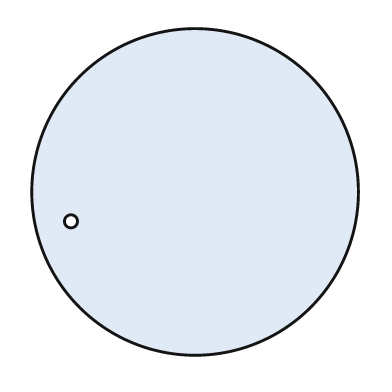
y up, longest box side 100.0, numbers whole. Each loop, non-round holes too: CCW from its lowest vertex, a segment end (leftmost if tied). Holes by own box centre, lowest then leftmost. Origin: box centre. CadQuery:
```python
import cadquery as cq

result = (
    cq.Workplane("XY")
    .moveTo(0.0, 0.0)
    .circle(50.0)
    .moveTo(-38.0, -9.0)
    .circle(2.0)
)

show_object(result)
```